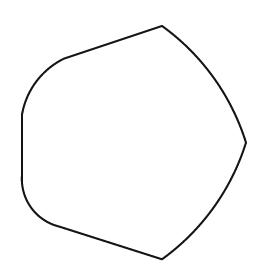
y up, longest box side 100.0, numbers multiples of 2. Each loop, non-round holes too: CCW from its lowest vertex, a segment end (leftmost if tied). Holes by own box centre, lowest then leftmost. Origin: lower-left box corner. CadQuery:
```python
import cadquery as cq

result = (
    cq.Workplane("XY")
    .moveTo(60.0, 0.0)
    .threePointArc((82.0, 22.0), (96.0, 50.0))
    .threePointArc((82.0, 78.0), (60.0, 100.0))
    .lineTo(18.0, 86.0)
    .threePointArc((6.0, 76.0), (0.0, 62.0))
    .lineTo(0.0, 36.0)
    .threePointArc((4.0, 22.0), (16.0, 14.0))
    .close()
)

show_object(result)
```